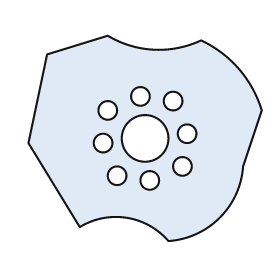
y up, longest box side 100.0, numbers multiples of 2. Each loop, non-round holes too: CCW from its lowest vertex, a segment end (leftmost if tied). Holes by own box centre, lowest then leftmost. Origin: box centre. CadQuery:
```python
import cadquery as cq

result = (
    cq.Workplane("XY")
    .moveTo(10.0, -44.0)
    .threePointArc((32.0, -34.0), (42.0, -12.0))
    .lineTo(50.0, 12.0)
    .threePointArc((40.0, 30.0), (24.0, 42.0))
    .threePointArc((4.0, 38.0), (-16.0, 44.0))
    .lineTo(-42.0, 36.0)
    .lineTo(-50.0, -2.0)
    .lineTo(-28.0, -38.0)
    .threePointArc((-8.0, -34.0), (10.0, -44.0))
    .close()
    .moveTo(2.0, -18.0)
    .circle(4.0)
    .moveTo(-12.0, -16.0)
    .circle(4.0)
    .moveTo(16.0, -12.0)
    .circle(4.0)
    .moveTo(-18.0, -2.0)
    .circle(4.0)
    .moveTo(0.0, 0.0)
    .circle(10.0)
    .moveTo(18.0, 2.0)
    .circle(4.0)
    .moveTo(-16.0, 12.0)
    .circle(4.0)
    .moveTo(12.0, 16.0)
    .circle(4.0)
    .moveTo(-2.0, 18.0)
    .circle(4.0)
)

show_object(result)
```